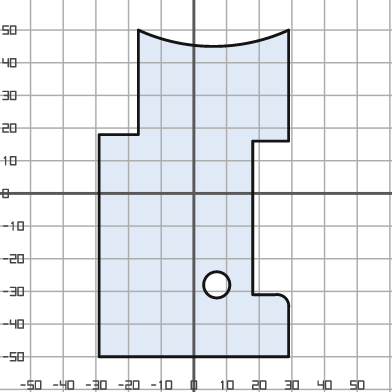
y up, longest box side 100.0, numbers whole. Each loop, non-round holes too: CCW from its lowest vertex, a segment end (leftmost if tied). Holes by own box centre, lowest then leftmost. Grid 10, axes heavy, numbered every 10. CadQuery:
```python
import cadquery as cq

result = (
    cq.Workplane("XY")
    .moveTo(-29.0, -50.0)
    .lineTo(29.0, -50.0)
    .lineTo(29.0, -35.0)
    .threePointArc((28.0, -32.0), (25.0, -31.0))
    .lineTo(18.0, -31.0)
    .lineTo(18.0, 16.0)
    .lineTo(29.0, 16.0)
    .lineTo(29.0, 50.0)
    .threePointArc((6.0, 45.0), (-17.0, 50.0))
    .lineTo(-17.0, 18.0)
    .lineTo(-29.0, 18.0)
    .close()
    .moveTo(7.0, -28.0)
    .circle(4.0)
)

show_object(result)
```